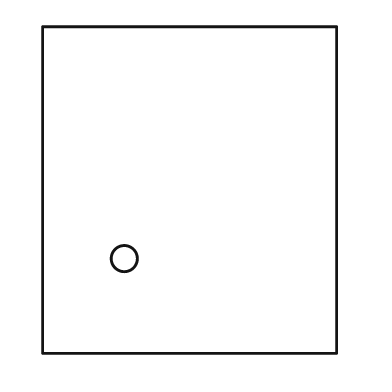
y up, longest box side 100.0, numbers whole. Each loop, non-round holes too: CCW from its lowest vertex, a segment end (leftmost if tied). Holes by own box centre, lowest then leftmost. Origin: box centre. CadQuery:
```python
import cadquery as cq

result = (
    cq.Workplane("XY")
    .moveTo(-45.0, -50.0)
    .lineTo(45.0, -50.0)
    .lineTo(45.0, 50.0)
    .lineTo(-45.0, 50.0)
    .close()
    .moveTo(-20.0, -21.0)
    .circle(4.0)
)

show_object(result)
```